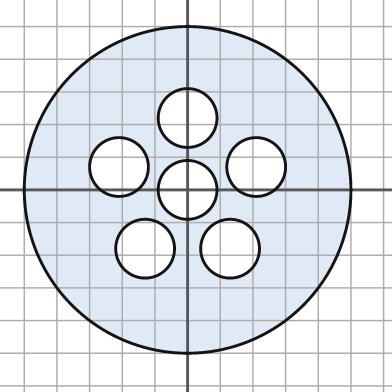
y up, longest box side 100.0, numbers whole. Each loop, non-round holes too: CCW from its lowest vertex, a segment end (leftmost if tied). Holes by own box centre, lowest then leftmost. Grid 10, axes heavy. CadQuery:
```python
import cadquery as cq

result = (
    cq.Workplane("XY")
    .moveTo(0.0, 0.0)
    .circle(50.0)
    .moveTo(-13.0, -18.0)
    .circle(9.0)
    .moveTo(13.0, -18.0)
    .circle(9.0)
    .moveTo(0.0, 0.0)
    .circle(9.0)
    .moveTo(-21.0, 7.0)
    .circle(9.0)
    .moveTo(21.0, 7.0)
    .circle(9.0)
    .moveTo(0.0, 22.0)
    .circle(9.0)
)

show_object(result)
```